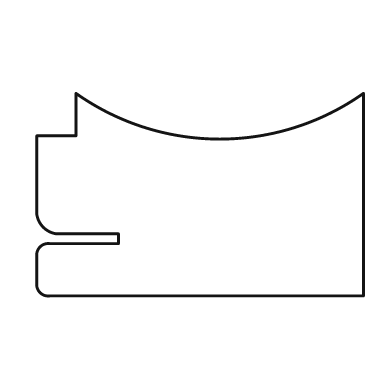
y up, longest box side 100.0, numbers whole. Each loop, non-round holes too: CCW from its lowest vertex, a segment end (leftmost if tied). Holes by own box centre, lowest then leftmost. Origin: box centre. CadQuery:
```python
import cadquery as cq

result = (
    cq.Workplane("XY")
    .moveTo(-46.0, -31.0)
    .lineTo(50.0, -31.0)
    .lineTo(50.0, 31.0)
    .threePointArc((6.0, 17.0), (-38.0, 31.0))
    .lineTo(-38.0, 18.0)
    .lineTo(-50.0, 18.0)
    .lineTo(-50.0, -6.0)
    .threePointArc((-48.0, -10.0), (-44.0, -12.0))
    .lineTo(-25.0, -12.0)
    .lineTo(-25.0, -15.0)
    .lineTo(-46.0, -15.0)
    .threePointArc((-49.0, -16.0), (-50.0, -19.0))
    .lineTo(-50.0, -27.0)
    .threePointArc((-49.0, -30.0), (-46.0, -31.0))
    .close()
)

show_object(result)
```